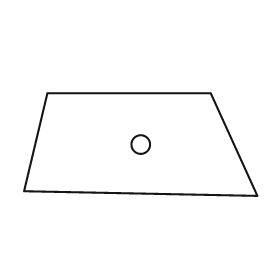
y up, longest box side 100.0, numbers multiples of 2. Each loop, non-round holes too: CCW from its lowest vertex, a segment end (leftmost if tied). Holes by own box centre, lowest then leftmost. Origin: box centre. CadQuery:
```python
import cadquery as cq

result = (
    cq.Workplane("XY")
    .moveTo(50.0, -22.0)
    .lineTo(30.0, 22.0)
    .lineTo(-40.0, 22.0)
    .lineTo(-50.0, -20.0)
    .close()
    .moveTo(0.0, 0.0)
    .circle(4.0)
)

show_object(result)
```